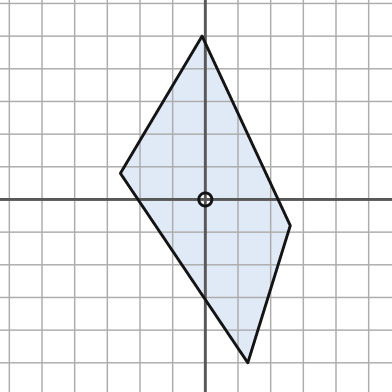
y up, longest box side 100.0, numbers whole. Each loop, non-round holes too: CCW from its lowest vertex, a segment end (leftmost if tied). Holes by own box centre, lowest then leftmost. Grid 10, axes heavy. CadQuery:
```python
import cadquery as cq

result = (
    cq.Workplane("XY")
    .moveTo(13.0, -50.0)
    .lineTo(26.0, -8.0)
    .lineTo(-1.0, 50.0)
    .lineTo(-26.0, 8.0)
    .close()
    .moveTo(0.0, 0.0)
    .circle(2.0)
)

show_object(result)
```